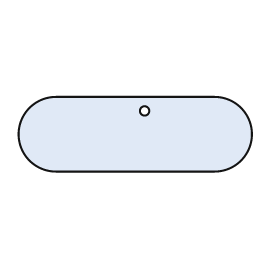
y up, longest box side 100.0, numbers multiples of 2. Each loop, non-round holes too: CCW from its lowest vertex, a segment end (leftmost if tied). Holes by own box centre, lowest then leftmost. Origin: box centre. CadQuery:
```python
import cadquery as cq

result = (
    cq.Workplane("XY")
    .moveTo(-34.0, -16.0)
    .lineTo(34.0, -16.0)
    .threePointArc((50.0, 0.0), (34.0, 16.0))
    .lineTo(-34.0, 16.0)
    .threePointArc((-50.0, 0.0), (-34.0, -16.0))
    .close()
    .moveTo(4.0, 10.0)
    .circle(2.0)
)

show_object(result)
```